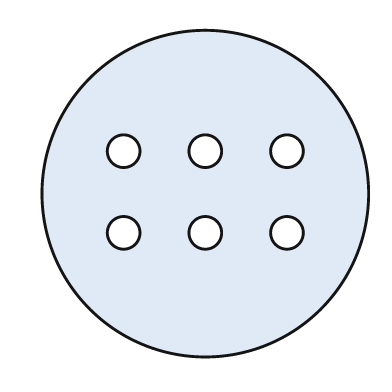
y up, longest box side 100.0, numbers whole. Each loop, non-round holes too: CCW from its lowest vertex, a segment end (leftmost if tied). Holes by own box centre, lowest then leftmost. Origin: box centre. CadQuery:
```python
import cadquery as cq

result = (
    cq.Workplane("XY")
    .moveTo(0.0, 0.0)
    .circle(50.0)
    .moveTo(-25.0, -12.0)
    .circle(5.0)
    .moveTo(0.0, -12.0)
    .circle(5.0)
    .moveTo(25.0, -12.0)
    .circle(5.0)
    .moveTo(-25.0, 13.0)
    .circle(5.0)
    .moveTo(0.0, 13.0)
    .circle(5.0)
    .moveTo(25.0, 13.0)
    .circle(5.0)
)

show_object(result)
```